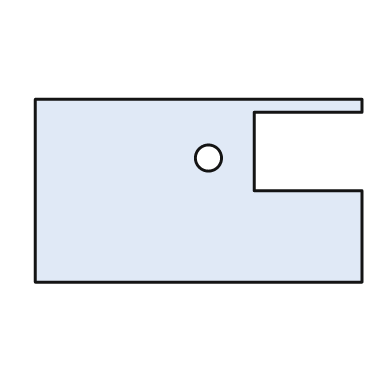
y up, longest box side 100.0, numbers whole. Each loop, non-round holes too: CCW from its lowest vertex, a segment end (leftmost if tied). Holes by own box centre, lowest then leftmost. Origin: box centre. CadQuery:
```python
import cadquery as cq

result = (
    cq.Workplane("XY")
    .moveTo(-50.0, -28.0)
    .lineTo(50.0, -28.0)
    .lineTo(50.0, 0.0)
    .lineTo(17.0, 0.0)
    .lineTo(17.0, 24.0)
    .lineTo(50.0, 24.0)
    .lineTo(50.0, 28.0)
    .lineTo(-50.0, 28.0)
    .close()
    .moveTo(3.0, 10.0)
    .circle(4.0)
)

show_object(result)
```